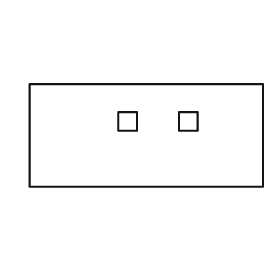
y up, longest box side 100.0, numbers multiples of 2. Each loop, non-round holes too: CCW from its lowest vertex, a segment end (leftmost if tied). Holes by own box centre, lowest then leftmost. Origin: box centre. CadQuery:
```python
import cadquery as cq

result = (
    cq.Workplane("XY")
    .moveTo(-50.0, -22.0)
    .lineTo(50.0, -22.0)
    .lineTo(50.0, 22.0)
    .lineTo(-50.0, 22.0)
    .close()
    .moveTo(-12.0, 2.0)
    .lineTo(-4.0, 2.0)
    .lineTo(-4.0, 10.0)
    .lineTo(-12.0, 10.0)
    .close()
    .moveTo(14.0, 2.0)
    .lineTo(22.0, 2.0)
    .lineTo(22.0, 10.0)
    .lineTo(14.0, 10.0)
    .close()
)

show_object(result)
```